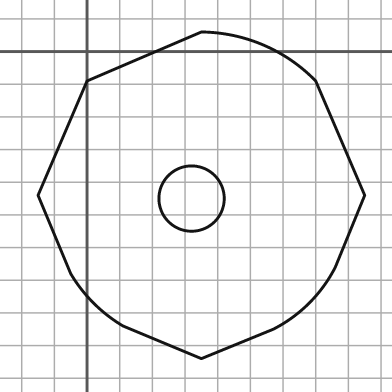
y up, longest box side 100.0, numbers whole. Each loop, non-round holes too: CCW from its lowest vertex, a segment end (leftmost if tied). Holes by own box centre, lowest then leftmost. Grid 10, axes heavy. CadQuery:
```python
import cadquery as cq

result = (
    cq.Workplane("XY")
    .moveTo(35.0, -94.0)
    .lineTo(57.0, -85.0)
    .threePointArc((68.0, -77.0), (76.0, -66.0))
    .lineTo(85.0, -44.0)
    .lineTo(70.0, -9.0)
    .threePointArc((54.0, 2.0), (35.0, 6.0))
    .lineTo(0.0, -9.0)
    .lineTo(-15.0, -44.0)
    .lineTo(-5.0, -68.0)
    .threePointArc((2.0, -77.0), (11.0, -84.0))
    .close()
    .moveTo(32.0, -45.0)
    .circle(10.0)
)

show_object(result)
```